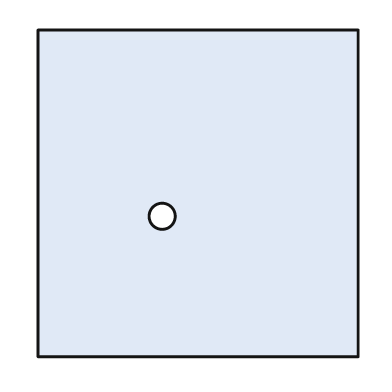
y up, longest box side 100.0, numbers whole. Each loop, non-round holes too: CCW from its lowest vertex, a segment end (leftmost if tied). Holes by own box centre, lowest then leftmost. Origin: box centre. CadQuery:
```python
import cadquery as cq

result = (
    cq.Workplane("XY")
    .moveTo(-49.0, -50.0)
    .lineTo(49.0, -50.0)
    .lineTo(49.0, 50.0)
    .lineTo(-49.0, 50.0)
    .close()
    .moveTo(-11.0, -7.0)
    .circle(4.0)
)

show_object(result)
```